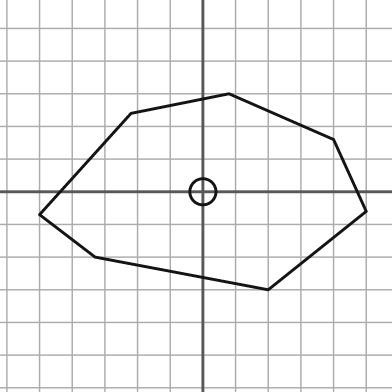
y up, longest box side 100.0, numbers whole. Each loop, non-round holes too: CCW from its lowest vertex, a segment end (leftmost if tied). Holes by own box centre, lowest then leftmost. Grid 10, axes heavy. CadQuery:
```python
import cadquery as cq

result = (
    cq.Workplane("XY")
    .moveTo(20.0, -30.0)
    .lineTo(50.0, -6.0)
    .lineTo(40.0, 16.0)
    .lineTo(8.0, 30.0)
    .lineTo(-22.0, 24.0)
    .lineTo(-50.0, -7.0)
    .lineTo(-33.0, -20.0)
    .close()
    .moveTo(0.0, 0.0)
    .circle(4.0)
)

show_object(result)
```